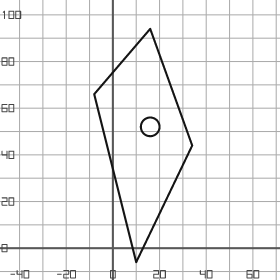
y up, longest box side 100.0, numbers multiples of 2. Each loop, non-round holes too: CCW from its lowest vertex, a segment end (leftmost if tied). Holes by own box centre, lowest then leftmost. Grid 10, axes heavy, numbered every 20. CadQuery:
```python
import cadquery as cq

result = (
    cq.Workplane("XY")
    .moveTo(10.0, -6.0)
    .lineTo(34.0, 44.0)
    .lineTo(16.0, 94.0)
    .lineTo(-8.0, 66.0)
    .close()
    .moveTo(16.0, 52.0)
    .circle(4.0)
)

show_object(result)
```